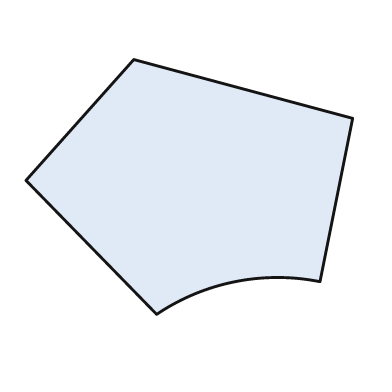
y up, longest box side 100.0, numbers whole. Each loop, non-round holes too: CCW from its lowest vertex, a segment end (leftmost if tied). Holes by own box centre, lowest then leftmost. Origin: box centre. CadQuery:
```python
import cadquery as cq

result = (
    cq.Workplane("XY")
    .moveTo(-10.0, -39.0)
    .threePointArc((14.0, -29.0), (40.0, -29.0))
    .lineTo(50.0, 21.0)
    .lineTo(-17.0, 39.0)
    .lineTo(-50.0, 2.0)
    .close()
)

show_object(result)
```